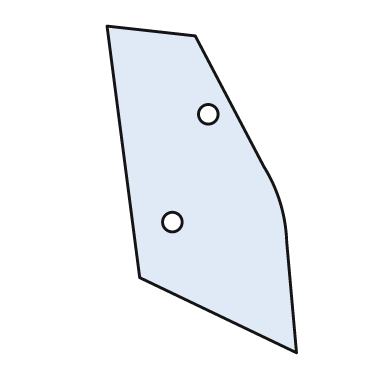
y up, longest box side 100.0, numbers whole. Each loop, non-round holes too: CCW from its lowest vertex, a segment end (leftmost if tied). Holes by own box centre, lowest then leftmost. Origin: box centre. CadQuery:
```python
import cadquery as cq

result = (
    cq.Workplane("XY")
    .moveTo(29.0, -50.0)
    .lineTo(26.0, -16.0)
    .threePointArc((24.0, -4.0), (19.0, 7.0))
    .lineTo(-2.0, 47.0)
    .lineTo(-29.0, 50.0)
    .lineTo(-19.0, -27.0)
    .close()
    .moveTo(-9.0, -10.0)
    .circle(3.0)
    .moveTo(2.0, 23.0)
    .circle(3.0)
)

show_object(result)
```